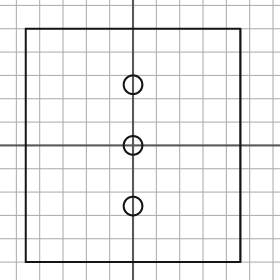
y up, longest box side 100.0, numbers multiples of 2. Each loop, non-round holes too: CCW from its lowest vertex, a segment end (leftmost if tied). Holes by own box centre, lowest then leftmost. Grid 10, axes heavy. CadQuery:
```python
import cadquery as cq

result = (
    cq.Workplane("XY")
    .moveTo(-46.0, -50.0)
    .lineTo(46.0, -50.0)
    .lineTo(46.0, 50.0)
    .lineTo(-46.0, 50.0)
    .close()
    .moveTo(0.0, -26.0)
    .circle(4.0)
    .moveTo(0.0, 0.0)
    .circle(4.0)
    .moveTo(0.0, 26.0)
    .circle(4.0)
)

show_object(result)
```